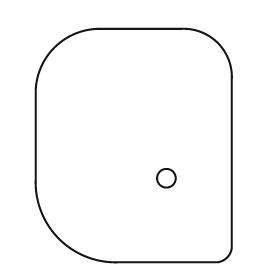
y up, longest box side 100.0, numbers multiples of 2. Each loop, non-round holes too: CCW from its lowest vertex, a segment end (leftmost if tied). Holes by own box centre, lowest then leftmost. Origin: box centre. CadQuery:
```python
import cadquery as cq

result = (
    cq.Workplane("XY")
    .moveTo(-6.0, -50.0)
    .lineTo(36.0, -50.0)
    .threePointArc((40.0, -48.0), (42.0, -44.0))
    .lineTo(42.0, 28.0)
    .threePointArc((36.0, 44.0), (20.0, 50.0))
    .lineTo(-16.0, 50.0)
    .threePointArc((-34.0, 42.0), (-42.0, 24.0))
    .lineTo(-42.0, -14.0)
    .threePointArc((-32.0, -40.0), (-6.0, -50.0))
    .close()
    .moveTo(14.0, -14.0)
    .circle(4.0)
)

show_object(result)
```